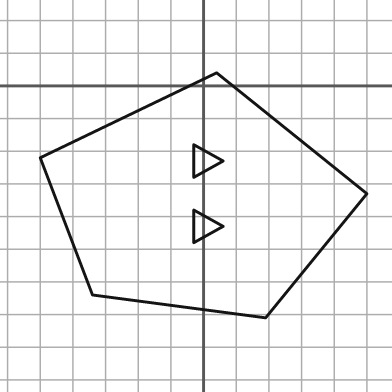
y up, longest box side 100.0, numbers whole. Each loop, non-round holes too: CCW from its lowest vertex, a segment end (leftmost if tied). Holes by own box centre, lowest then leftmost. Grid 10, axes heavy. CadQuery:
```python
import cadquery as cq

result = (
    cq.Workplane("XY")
    .moveTo(19.0, -71.0)
    .lineTo(50.0, -33.0)
    .lineTo(4.0, 4.0)
    .lineTo(-50.0, -22.0)
    .lineTo(-34.0, -64.0)
    .close()
    .moveTo(-3.0, -48.0)
    .lineTo(6.0, -43.0)
    .lineTo(-3.0, -38.0)
    .close()
    .moveTo(-3.0, -28.0)
    .lineTo(6.0, -23.0)
    .lineTo(-3.0, -18.0)
    .close()
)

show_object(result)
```